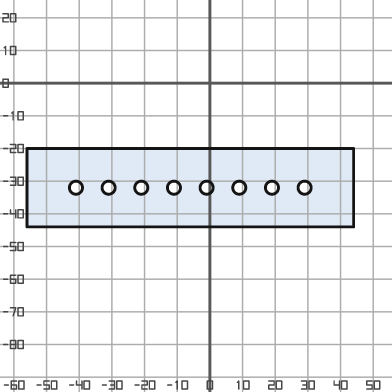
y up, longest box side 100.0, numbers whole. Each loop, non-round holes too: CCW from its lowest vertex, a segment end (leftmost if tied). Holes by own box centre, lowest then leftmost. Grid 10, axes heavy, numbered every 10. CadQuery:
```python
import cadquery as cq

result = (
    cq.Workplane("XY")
    .moveTo(-56.0, -44.0)
    .lineTo(44.0, -44.0)
    .lineTo(44.0, -20.0)
    .lineTo(-56.0, -20.0)
    .close()
    .moveTo(-41.0, -32.0)
    .circle(2.0)
    .moveTo(-31.0, -32.0)
    .circle(2.0)
    .moveTo(-21.0, -32.0)
    .circle(2.0)
    .moveTo(-11.0, -32.0)
    .circle(2.0)
    .moveTo(-1.0, -32.0)
    .circle(2.0)
    .moveTo(9.0, -32.0)
    .circle(2.0)
    .moveTo(19.0, -32.0)
    .circle(2.0)
    .moveTo(29.0, -32.0)
    .circle(2.0)
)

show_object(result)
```